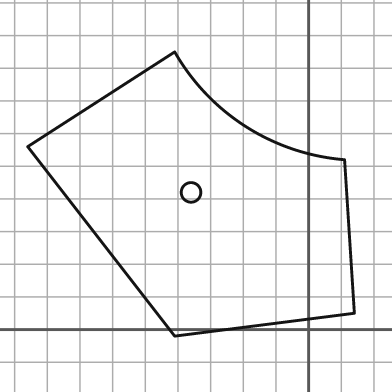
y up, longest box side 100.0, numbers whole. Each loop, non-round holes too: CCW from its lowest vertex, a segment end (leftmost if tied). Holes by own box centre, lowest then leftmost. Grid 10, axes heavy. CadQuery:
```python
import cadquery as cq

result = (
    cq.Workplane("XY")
    .moveTo(-41.0, -2.0)
    .lineTo(14.0, 5.0)
    .lineTo(11.0, 52.0)
    .threePointArc((-19.0, 62.0), (-41.0, 85.0))
    .lineTo(-86.0, 56.0)
    .close()
    .moveTo(-36.0, 42.0)
    .circle(3.0)
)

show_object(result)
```